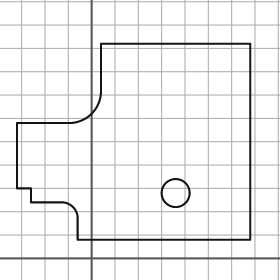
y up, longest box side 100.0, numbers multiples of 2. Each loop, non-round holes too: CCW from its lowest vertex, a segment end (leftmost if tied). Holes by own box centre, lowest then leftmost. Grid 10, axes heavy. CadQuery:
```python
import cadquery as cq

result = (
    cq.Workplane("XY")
    .moveTo(-6.0, 8.0)
    .lineTo(68.0, 8.0)
    .lineTo(68.0, 92.0)
    .lineTo(4.0, 92.0)
    .lineTo(4.0, 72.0)
    .threePointArc((0.0, 62.0), (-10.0, 58.0))
    .lineTo(-32.0, 58.0)
    .lineTo(-32.0, 30.0)
    .lineTo(-26.0, 30.0)
    .lineTo(-26.0, 24.0)
    .lineTo(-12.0, 24.0)
    .threePointArc((-8.0, 22.0), (-6.0, 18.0))
    .close()
    .moveTo(36.0, 28.0)
    .circle(6.0)
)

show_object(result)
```